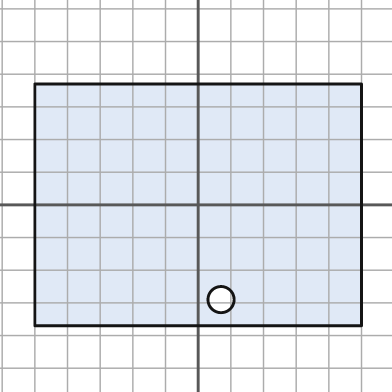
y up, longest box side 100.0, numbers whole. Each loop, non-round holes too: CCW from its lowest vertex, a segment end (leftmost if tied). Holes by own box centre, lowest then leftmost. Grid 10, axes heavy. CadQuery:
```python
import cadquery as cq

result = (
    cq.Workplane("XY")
    .moveTo(-50.0, -37.0)
    .lineTo(50.0, -37.0)
    .lineTo(50.0, 37.0)
    .lineTo(-50.0, 37.0)
    .close()
    .moveTo(7.0, -29.0)
    .circle(4.0)
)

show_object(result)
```